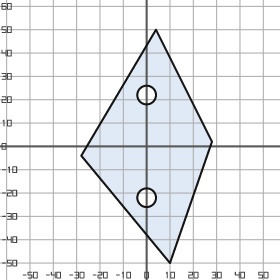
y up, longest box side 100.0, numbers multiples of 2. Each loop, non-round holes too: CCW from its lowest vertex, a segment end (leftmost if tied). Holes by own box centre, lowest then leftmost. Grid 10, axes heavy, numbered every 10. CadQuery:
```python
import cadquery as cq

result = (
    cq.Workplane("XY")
    .moveTo(10.0, -50.0)
    .lineTo(28.0, 2.0)
    .lineTo(4.0, 50.0)
    .lineTo(-28.0, -4.0)
    .close()
    .moveTo(0.0, -22.0)
    .circle(4.0)
    .moveTo(0.0, 22.0)
    .circle(4.0)
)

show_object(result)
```